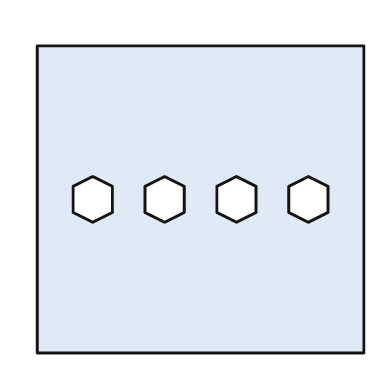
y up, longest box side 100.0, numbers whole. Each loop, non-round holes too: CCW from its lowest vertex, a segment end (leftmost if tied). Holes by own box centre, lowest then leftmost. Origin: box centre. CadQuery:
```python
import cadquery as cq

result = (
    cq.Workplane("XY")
    .moveTo(-50.0, -47.0)
    .lineTo(50.0, -47.0)
    .lineTo(50.0, 47.0)
    .lineTo(-50.0, 47.0)
    .close()
    .moveTo(-33.0, -7.0)
    .lineTo(-27.0, -4.0)
    .lineTo(-27.0, 4.0)
    .lineTo(-33.0, 7.0)
    .lineTo(-39.0, 4.0)
    .lineTo(-39.0, -4.0)
    .close()
    .moveTo(-11.0, -7.0)
    .lineTo(-5.0, -4.0)
    .lineTo(-5.0, 4.0)
    .lineTo(-11.0, 7.0)
    .lineTo(-17.0, 4.0)
    .lineTo(-17.0, -4.0)
    .close()
    .moveTo(11.0, -7.0)
    .lineTo(17.0, -4.0)
    .lineTo(17.0, 4.0)
    .lineTo(11.0, 7.0)
    .lineTo(5.0, 4.0)
    .lineTo(5.0, -4.0)
    .close()
    .moveTo(33.0, -7.0)
    .lineTo(39.0, -4.0)
    .lineTo(39.0, 4.0)
    .lineTo(33.0, 7.0)
    .lineTo(27.0, 4.0)
    .lineTo(27.0, -4.0)
    .close()
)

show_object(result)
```